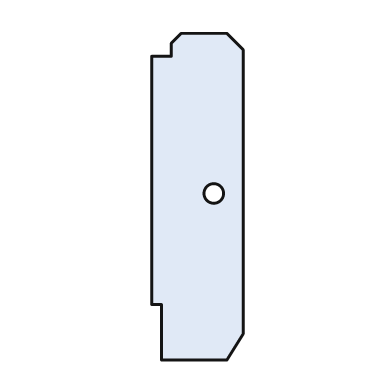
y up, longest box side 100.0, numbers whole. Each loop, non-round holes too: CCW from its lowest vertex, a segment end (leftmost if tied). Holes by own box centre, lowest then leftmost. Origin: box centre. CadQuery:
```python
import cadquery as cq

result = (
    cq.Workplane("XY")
    .moveTo(-11.0, -50.0)
    .lineTo(9.0, -50.0)
    .lineTo(14.0, -42.0)
    .lineTo(14.0, 45.0)
    .lineTo(9.0, 50.0)
    .lineTo(-5.0, 50.0)
    .lineTo(-8.0, 47.0)
    .lineTo(-8.0, 43.0)
    .lineTo(-14.0, 43.0)
    .lineTo(-14.0, -33.0)
    .lineTo(-11.0, -33.0)
    .close()
    .moveTo(5.0, 1.0)
    .circle(3.0)
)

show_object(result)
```